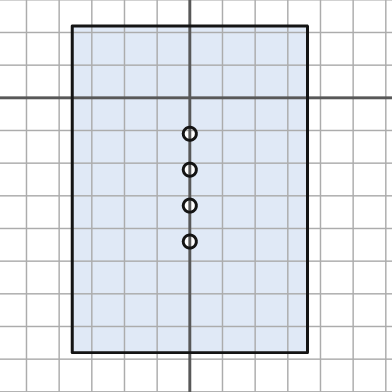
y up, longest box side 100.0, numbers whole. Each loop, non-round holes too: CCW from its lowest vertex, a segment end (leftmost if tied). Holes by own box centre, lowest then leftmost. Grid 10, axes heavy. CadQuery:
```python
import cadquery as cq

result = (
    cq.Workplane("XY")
    .moveTo(-36.0, -78.0)
    .lineTo(36.0, -78.0)
    .lineTo(36.0, 22.0)
    .lineTo(-36.0, 22.0)
    .close()
    .moveTo(0.0, -44.0)
    .circle(2.0)
    .moveTo(0.0, -33.0)
    .circle(2.0)
    .moveTo(0.0, -22.0)
    .circle(2.0)
    .moveTo(0.0, -11.0)
    .circle(2.0)
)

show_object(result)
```